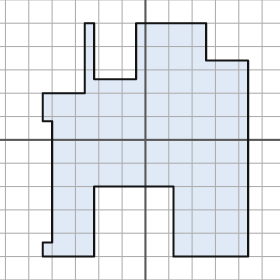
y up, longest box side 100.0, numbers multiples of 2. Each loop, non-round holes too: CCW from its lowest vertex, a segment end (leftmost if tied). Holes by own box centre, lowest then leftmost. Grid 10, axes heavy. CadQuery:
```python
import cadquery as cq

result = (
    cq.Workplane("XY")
    .moveTo(-44.0, -50.0)
    .lineTo(-22.0, -50.0)
    .lineTo(-22.0, -20.0)
    .lineTo(12.0, -20.0)
    .lineTo(12.0, -50.0)
    .lineTo(44.0, -50.0)
    .lineTo(44.0, 34.0)
    .lineTo(26.0, 34.0)
    .lineTo(26.0, 50.0)
    .lineTo(-4.0, 50.0)
    .lineTo(-4.0, 26.0)
    .lineTo(-22.0, 26.0)
    .lineTo(-22.0, 50.0)
    .lineTo(-26.0, 50.0)
    .lineTo(-26.0, 20.0)
    .lineTo(-44.0, 20.0)
    .lineTo(-44.0, 8.0)
    .lineTo(-40.0, 8.0)
    .lineTo(-40.0, -44.0)
    .lineTo(-44.0, -44.0)
    .close()
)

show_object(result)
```